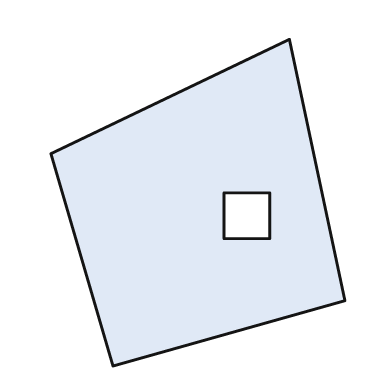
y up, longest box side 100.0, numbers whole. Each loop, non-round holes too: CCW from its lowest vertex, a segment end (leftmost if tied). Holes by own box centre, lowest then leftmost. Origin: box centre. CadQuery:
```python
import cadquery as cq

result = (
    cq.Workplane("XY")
    .moveTo(-26.0, -50.0)
    .lineTo(45.0, -30.0)
    .lineTo(28.0, 50.0)
    .lineTo(-45.0, 15.0)
    .close()
    .moveTo(8.0, -11.0)
    .lineTo(22.0, -11.0)
    .lineTo(22.0, 3.0)
    .lineTo(8.0, 3.0)
    .close()
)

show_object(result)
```